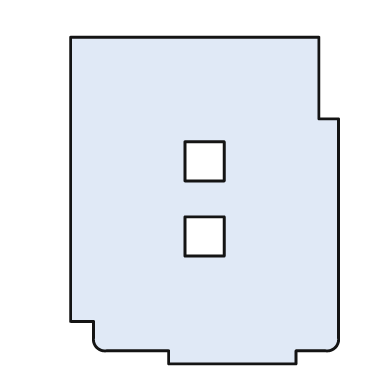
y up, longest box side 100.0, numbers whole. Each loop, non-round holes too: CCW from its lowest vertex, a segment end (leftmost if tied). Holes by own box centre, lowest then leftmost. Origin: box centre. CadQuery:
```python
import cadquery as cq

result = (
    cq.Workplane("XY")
    .moveTo(-11.0, -50.0)
    .lineTo(28.0, -50.0)
    .lineTo(28.0, -46.0)
    .lineTo(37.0, -46.0)
    .threePointArc((40.0, -45.0), (41.0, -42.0))
    .lineTo(41.0, 25.0)
    .lineTo(35.0, 25.0)
    .lineTo(35.0, 50.0)
    .lineTo(-41.0, 50.0)
    .lineTo(-41.0, -37.0)
    .lineTo(-34.0, -37.0)
    .lineTo(-34.0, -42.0)
    .threePointArc((-33.0, -45.0), (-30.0, -46.0))
    .lineTo(-11.0, -46.0)
    .close()
    .moveTo(-6.0, -17.0)
    .lineTo(6.0, -17.0)
    .lineTo(6.0, -5.0)
    .lineTo(-6.0, -5.0)
    .close()
    .moveTo(-6.0, 6.0)
    .lineTo(6.0, 6.0)
    .lineTo(6.0, 18.0)
    .lineTo(-6.0, 18.0)
    .close()
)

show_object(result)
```